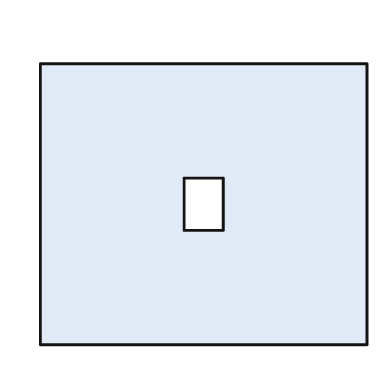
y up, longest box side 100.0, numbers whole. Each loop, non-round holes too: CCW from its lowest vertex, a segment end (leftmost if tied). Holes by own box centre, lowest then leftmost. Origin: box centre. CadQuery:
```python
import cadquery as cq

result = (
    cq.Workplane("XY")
    .moveTo(-50.0, -43.0)
    .lineTo(50.0, -43.0)
    .lineTo(50.0, 43.0)
    .lineTo(-50.0, 43.0)
    .close()
    .moveTo(-6.0, -8.0)
    .lineTo(6.0, -8.0)
    .lineTo(6.0, 8.0)
    .lineTo(-6.0, 8.0)
    .close()
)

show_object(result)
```